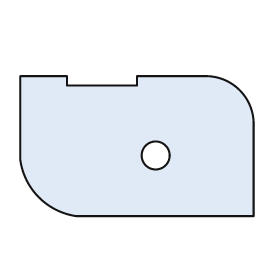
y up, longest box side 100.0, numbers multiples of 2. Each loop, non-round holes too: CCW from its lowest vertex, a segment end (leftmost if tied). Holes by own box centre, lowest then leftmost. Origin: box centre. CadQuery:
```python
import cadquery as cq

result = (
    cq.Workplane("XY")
    .moveTo(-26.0, -30.0)
    .lineTo(50.0, -30.0)
    .lineTo(50.0, 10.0)
    .threePointArc((44.0, 24.0), (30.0, 30.0))
    .lineTo(0.0, 30.0)
    .lineTo(0.0, 26.0)
    .lineTo(-30.0, 26.0)
    .lineTo(-30.0, 30.0)
    .lineTo(-50.0, 30.0)
    .lineTo(-50.0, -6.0)
    .threePointArc((-42.0, -22.0), (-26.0, -30.0))
    .close()
    .moveTo(8.0, -4.0)
    .circle(6.0)
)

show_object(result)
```